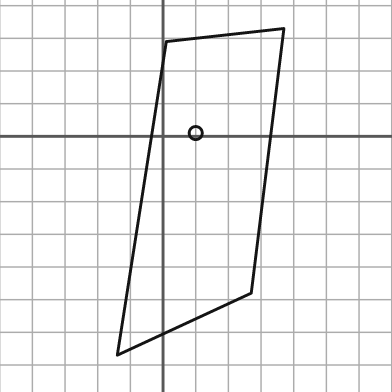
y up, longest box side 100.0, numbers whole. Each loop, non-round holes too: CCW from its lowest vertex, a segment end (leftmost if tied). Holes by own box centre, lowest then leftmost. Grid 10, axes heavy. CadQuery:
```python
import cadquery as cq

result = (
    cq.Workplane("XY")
    .moveTo(-14.0, -67.0)
    .lineTo(27.0, -48.0)
    .lineTo(37.0, 33.0)
    .lineTo(1.0, 29.0)
    .close()
    .moveTo(10.0, 1.0)
    .circle(2.0)
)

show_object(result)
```